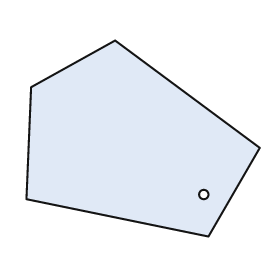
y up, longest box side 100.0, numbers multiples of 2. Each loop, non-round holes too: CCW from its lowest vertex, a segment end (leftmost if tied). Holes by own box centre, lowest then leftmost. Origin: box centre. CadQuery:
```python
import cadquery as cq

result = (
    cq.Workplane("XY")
    .moveTo(28.0, -42.0)
    .lineTo(50.0, -4.0)
    .lineTo(-12.0, 42.0)
    .lineTo(-48.0, 22.0)
    .lineTo(-50.0, -26.0)
    .close()
    .moveTo(26.0, -24.0)
    .circle(2.0)
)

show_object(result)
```